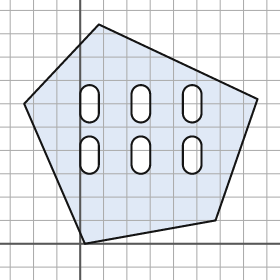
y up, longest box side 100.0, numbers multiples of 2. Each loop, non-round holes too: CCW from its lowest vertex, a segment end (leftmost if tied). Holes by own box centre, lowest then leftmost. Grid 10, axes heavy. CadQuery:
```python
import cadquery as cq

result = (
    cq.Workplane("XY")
    .moveTo(2.0, 0.0)
    .lineTo(58.0, 10.0)
    .lineTo(76.0, 62.0)
    .lineTo(8.0, 94.0)
    .lineTo(-24.0, 60.0)
    .close()
    .moveTo(0.0, 34.0)
    .threePointArc((4.0, 30.0), (8.0, 34.0))
    .lineTo(8.0, 42.0)
    .threePointArc((4.0, 46.0), (0.0, 42.0))
    .close()
    .moveTo(22.0, 34.0)
    .threePointArc((26.0, 30.0), (30.0, 34.0))
    .lineTo(30.0, 42.0)
    .threePointArc((26.0, 46.0), (22.0, 42.0))
    .close()
    .moveTo(44.0, 34.0)
    .threePointArc((48.0, 30.0), (52.0, 34.0))
    .lineTo(52.0, 42.0)
    .threePointArc((48.0, 46.0), (44.0, 42.0))
    .close()
    .moveTo(0.0, 56.0)
    .threePointArc((4.0, 52.0), (8.0, 56.0))
    .lineTo(8.0, 64.0)
    .threePointArc((4.0, 68.0), (0.0, 64.0))
    .close()
    .moveTo(22.0, 56.0)
    .threePointArc((26.0, 52.0), (30.0, 56.0))
    .lineTo(30.0, 64.0)
    .threePointArc((26.0, 68.0), (22.0, 64.0))
    .close()
    .moveTo(44.0, 56.0)
    .threePointArc((48.0, 52.0), (52.0, 56.0))
    .lineTo(52.0, 64.0)
    .threePointArc((48.0, 68.0), (44.0, 64.0))
    .close()
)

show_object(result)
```